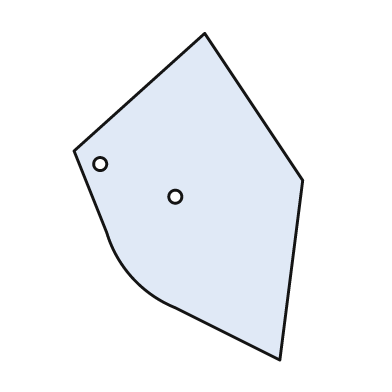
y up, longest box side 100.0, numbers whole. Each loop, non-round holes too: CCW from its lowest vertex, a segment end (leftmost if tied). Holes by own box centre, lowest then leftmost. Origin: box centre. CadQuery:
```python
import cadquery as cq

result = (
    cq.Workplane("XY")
    .moveTo(28.0, -50.0)
    .lineTo(35.0, 5.0)
    .lineTo(5.0, 50.0)
    .lineTo(-35.0, 14.0)
    .lineTo(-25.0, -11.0)
    .threePointArc((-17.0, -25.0), (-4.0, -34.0))
    .close()
    .moveTo(-4.0, 0.0)
    .circle(2.0)
    .moveTo(-27.0, 10.0)
    .circle(2.0)
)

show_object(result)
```